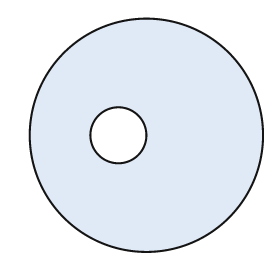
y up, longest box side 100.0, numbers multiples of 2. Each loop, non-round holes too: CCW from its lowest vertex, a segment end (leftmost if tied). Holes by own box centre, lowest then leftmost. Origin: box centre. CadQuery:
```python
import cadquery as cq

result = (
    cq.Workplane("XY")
    .moveTo(0.0, 0.0)
    .circle(50.0)
    .moveTo(-12.0, 0.0)
    .circle(12.0)
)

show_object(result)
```